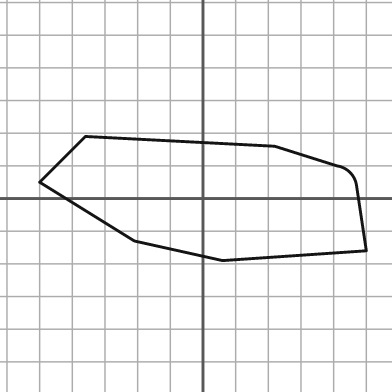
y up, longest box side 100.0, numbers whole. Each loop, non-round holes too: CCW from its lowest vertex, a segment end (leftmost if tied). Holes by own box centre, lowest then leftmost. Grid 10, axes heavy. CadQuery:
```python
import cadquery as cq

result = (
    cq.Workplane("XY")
    .moveTo(6.0, -19.0)
    .lineTo(50.0, -16.0)
    .lineTo(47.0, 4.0)
    .threePointArc((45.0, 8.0), (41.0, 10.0))
    .lineTo(22.0, 16.0)
    .lineTo(-36.0, 19.0)
    .lineTo(-50.0, 5.0)
    .lineTo(-21.0, -13.0)
    .close()
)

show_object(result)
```